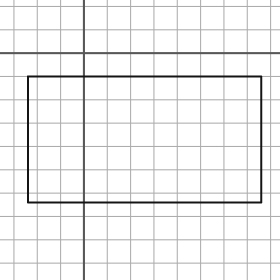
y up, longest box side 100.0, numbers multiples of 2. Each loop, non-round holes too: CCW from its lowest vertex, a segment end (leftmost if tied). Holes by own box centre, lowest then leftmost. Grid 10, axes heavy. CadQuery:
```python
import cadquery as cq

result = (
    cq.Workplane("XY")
    .moveTo(-24.0, -64.0)
    .lineTo(76.0, -64.0)
    .lineTo(76.0, -10.0)
    .lineTo(-24.0, -10.0)
    .close()
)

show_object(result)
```